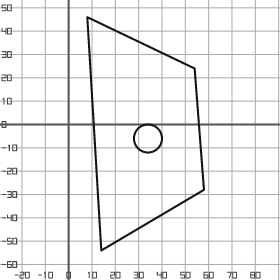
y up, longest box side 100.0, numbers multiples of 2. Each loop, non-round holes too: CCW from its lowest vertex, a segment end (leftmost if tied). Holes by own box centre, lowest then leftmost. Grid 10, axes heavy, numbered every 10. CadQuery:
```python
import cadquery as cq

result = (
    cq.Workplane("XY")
    .moveTo(14.0, -54.0)
    .lineTo(58.0, -28.0)
    .lineTo(54.0, 24.0)
    .lineTo(8.0, 46.0)
    .close()
    .moveTo(34.0, -6.0)
    .circle(6.0)
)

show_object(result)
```